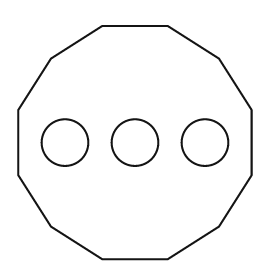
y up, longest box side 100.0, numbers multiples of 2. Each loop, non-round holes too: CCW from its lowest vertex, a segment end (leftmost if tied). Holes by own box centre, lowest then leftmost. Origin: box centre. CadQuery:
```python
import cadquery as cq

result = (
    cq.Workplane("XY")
    .moveTo(-14.0, -50.0)
    .lineTo(14.0, -50.0)
    .lineTo(36.0, -36.0)
    .lineTo(50.0, -14.0)
    .lineTo(50.0, 14.0)
    .lineTo(36.0, 36.0)
    .lineTo(14.0, 50.0)
    .lineTo(-14.0, 50.0)
    .lineTo(-36.0, 36.0)
    .lineTo(-50.0, 14.0)
    .lineTo(-50.0, -14.0)
    .lineTo(-36.0, -36.0)
    .close()
    .moveTo(-30.0, 0.0)
    .circle(10.0)
    .moveTo(0.0, 0.0)
    .circle(10.0)
    .moveTo(30.0, 0.0)
    .circle(10.0)
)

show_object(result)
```